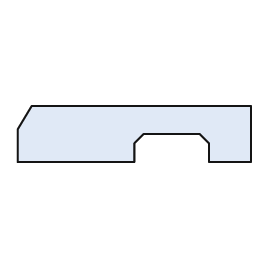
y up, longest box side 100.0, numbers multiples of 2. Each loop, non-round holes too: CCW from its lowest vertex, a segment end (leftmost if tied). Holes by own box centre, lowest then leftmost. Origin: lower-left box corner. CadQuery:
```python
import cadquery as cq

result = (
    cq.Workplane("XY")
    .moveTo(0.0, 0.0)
    .lineTo(50.0, 0.0)
    .lineTo(50.0, 8.0)
    .lineTo(54.0, 12.0)
    .lineTo(78.0, 12.0)
    .lineTo(82.0, 8.0)
    .lineTo(82.0, 0.0)
    .lineTo(100.0, 0.0)
    .lineTo(100.0, 24.0)
    .lineTo(6.0, 24.0)
    .lineTo(0.0, 14.0)
    .close()
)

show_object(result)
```